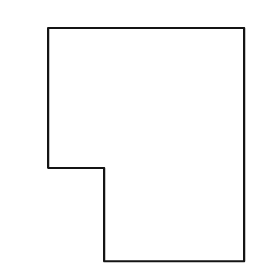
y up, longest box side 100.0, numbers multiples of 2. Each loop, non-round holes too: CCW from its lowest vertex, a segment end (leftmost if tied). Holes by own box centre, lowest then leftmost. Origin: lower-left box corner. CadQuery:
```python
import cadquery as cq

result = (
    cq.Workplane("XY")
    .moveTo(24.0, 0.0)
    .lineTo(84.0, 0.0)
    .lineTo(84.0, 100.0)
    .lineTo(0.0, 100.0)
    .lineTo(0.0, 40.0)
    .lineTo(24.0, 40.0)
    .close()
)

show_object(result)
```